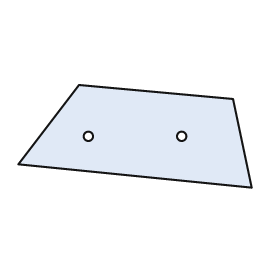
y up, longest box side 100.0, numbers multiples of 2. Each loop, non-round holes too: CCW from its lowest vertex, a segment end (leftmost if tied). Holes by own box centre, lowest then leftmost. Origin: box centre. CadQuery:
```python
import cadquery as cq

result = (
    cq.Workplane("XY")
    .moveTo(50.0, -22.0)
    .lineTo(42.0, 16.0)
    .lineTo(-24.0, 22.0)
    .lineTo(-50.0, -12.0)
    .close()
    .moveTo(-20.0, 0.0)
    .circle(2.0)
    .moveTo(20.0, 0.0)
    .circle(2.0)
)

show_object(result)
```